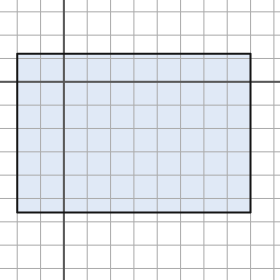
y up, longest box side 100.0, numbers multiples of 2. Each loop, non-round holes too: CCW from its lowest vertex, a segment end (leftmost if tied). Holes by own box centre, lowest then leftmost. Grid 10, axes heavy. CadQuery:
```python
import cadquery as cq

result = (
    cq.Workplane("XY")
    .moveTo(-20.0, -56.0)
    .lineTo(80.0, -56.0)
    .lineTo(80.0, 12.0)
    .lineTo(-20.0, 12.0)
    .close()
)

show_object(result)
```